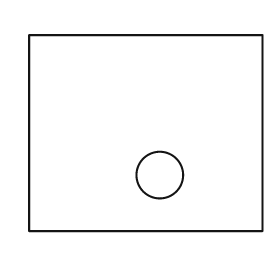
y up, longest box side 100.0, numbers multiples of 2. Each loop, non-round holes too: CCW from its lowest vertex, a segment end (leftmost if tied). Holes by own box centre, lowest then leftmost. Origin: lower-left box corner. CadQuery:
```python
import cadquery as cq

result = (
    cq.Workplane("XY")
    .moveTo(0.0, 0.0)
    .lineTo(100.0, 0.0)
    .lineTo(100.0, 84.0)
    .lineTo(0.0, 84.0)
    .close()
    .moveTo(56.0, 24.0)
    .circle(10.0)
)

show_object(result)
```